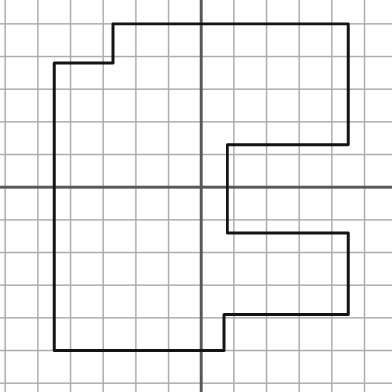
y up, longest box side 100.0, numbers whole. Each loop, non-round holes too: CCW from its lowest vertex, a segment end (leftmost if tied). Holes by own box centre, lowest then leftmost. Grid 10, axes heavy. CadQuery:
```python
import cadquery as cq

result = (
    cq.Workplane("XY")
    .moveTo(-45.0, -50.0)
    .lineTo(7.0, -50.0)
    .lineTo(7.0, -39.0)
    .lineTo(45.0, -39.0)
    .lineTo(45.0, -14.0)
    .lineTo(8.0, -14.0)
    .lineTo(8.0, 13.0)
    .lineTo(45.0, 13.0)
    .lineTo(45.0, 50.0)
    .lineTo(-27.0, 50.0)
    .lineTo(-27.0, 38.0)
    .lineTo(-45.0, 38.0)
    .close()
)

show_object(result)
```